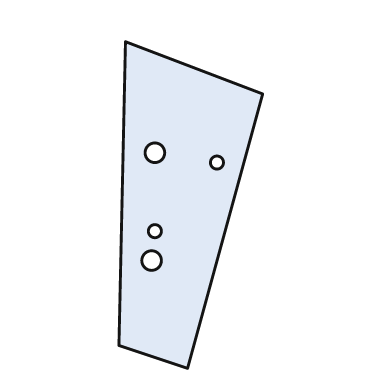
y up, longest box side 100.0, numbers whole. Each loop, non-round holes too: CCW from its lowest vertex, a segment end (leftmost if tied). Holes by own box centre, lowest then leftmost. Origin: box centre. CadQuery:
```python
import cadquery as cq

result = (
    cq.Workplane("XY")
    .moveTo(-1.0, -50.0)
    .lineTo(22.0, 34.0)
    .lineTo(-20.0, 50.0)
    .lineTo(-22.0, -43.0)
    .close()
    .moveTo(-12.0, -17.0)
    .circle(3.0)
    .moveTo(-11.0, -8.0)
    .circle(2.0)
    .moveTo(8.0, 13.0)
    .circle(2.0)
    .moveTo(-11.0, 16.0)
    .circle(3.0)
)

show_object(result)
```